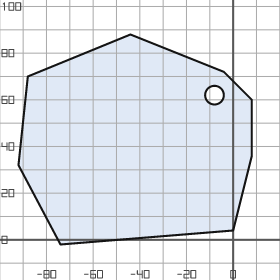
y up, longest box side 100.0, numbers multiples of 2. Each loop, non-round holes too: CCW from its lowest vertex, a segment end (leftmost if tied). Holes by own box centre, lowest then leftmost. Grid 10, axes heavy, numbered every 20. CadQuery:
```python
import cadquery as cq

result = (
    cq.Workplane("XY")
    .moveTo(-74.0, -2.0)
    .lineTo(0.0, 4.0)
    .lineTo(8.0, 36.0)
    .lineTo(8.0, 60.0)
    .lineTo(-4.0, 72.0)
    .lineTo(-44.0, 88.0)
    .lineTo(-88.0, 70.0)
    .lineTo(-92.0, 32.0)
    .close()
    .moveTo(-8.0, 62.0)
    .circle(4.0)
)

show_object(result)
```